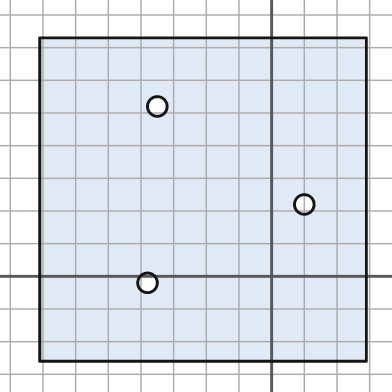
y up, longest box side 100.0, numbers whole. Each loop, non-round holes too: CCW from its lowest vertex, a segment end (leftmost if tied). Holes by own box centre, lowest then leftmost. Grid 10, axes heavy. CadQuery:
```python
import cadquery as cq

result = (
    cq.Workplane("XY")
    .moveTo(-71.0, -26.0)
    .lineTo(29.0, -26.0)
    .lineTo(29.0, 73.0)
    .lineTo(-71.0, 73.0)
    .close()
    .moveTo(-38.0, -2.0)
    .circle(3.0)
    .moveTo(10.0, 22.0)
    .circle(3.0)
    .moveTo(-35.0, 52.0)
    .circle(3.0)
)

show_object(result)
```